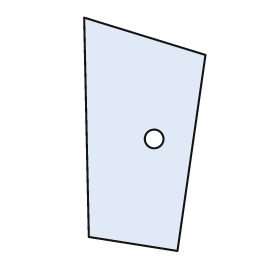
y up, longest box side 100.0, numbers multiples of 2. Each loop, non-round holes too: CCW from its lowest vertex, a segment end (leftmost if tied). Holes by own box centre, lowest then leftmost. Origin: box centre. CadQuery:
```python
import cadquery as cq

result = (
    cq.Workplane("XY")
    .moveTo(14.0, -50.0)
    .lineTo(26.0, 34.0)
    .lineTo(-26.0, 50.0)
    .lineTo(-24.0, -44.0)
    .close()
    .moveTo(4.0, -2.0)
    .circle(4.0)
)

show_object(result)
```